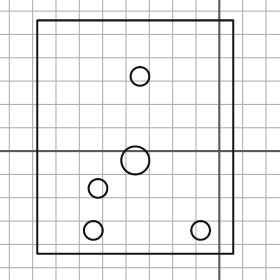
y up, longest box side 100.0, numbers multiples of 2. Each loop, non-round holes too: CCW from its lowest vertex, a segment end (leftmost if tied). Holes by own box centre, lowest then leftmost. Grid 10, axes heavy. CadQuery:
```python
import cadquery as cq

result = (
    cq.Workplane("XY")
    .moveTo(-78.0, -44.0)
    .lineTo(6.0, -44.0)
    .lineTo(6.0, 56.0)
    .lineTo(-78.0, 56.0)
    .close()
    .moveTo(-54.0, -34.0)
    .circle(4.0)
    .moveTo(-8.0, -34.0)
    .circle(4.0)
    .moveTo(-52.0, -16.0)
    .circle(4.0)
    .moveTo(-36.0, -4.0)
    .circle(6.0)
    .moveTo(-34.0, 32.0)
    .circle(4.0)
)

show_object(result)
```